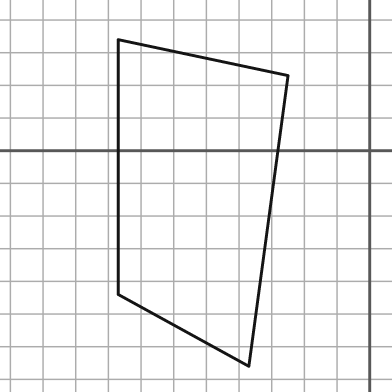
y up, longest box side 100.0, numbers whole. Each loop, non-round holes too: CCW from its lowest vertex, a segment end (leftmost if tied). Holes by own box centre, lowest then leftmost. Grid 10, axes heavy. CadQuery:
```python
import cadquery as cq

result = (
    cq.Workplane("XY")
    .moveTo(-37.0, -66.0)
    .lineTo(-25.0, 23.0)
    .lineTo(-77.0, 34.0)
    .lineTo(-77.0, -44.0)
    .close()
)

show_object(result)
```